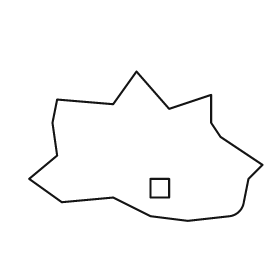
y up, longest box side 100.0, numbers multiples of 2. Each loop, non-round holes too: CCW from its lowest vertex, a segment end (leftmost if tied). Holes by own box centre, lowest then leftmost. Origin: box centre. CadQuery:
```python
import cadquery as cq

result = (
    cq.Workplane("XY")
    .moveTo(18.0, -32.0)
    .lineTo(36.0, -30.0)
    .threePointArc((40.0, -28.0), (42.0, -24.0))
    .lineTo(44.0, -14.0)
    .lineTo(50.0, -8.0)
    .lineTo(32.0, 4.0)
    .lineTo(28.0, 10.0)
    .lineTo(28.0, 22.0)
    .lineTo(10.0, 16.0)
    .lineTo(-4.0, 32.0)
    .lineTo(-14.0, 18.0)
    .lineTo(-38.0, 20.0)
    .lineTo(-40.0, 10.0)
    .lineTo(-38.0, -4.0)
    .lineTo(-50.0, -14.0)
    .lineTo(-36.0, -24.0)
    .lineTo(-14.0, -22.0)
    .lineTo(2.0, -30.0)
    .close()
    .moveTo(2.0, -22.0)
    .lineTo(10.0, -22.0)
    .lineTo(10.0, -14.0)
    .lineTo(2.0, -14.0)
    .close()
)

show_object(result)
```